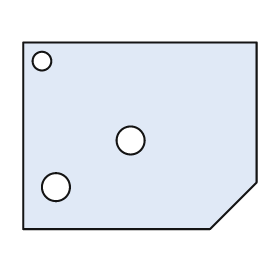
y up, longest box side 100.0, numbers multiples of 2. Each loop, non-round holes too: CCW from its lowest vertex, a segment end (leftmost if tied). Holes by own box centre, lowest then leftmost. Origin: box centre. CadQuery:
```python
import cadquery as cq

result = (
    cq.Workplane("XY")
    .moveTo(-50.0, -40.0)
    .lineTo(30.0, -40.0)
    .lineTo(50.0, -20.0)
    .lineTo(50.0, 40.0)
    .lineTo(-50.0, 40.0)
    .close()
    .moveTo(-36.0, -22.0)
    .circle(6.0)
    .moveTo(-4.0, -2.0)
    .circle(6.0)
    .moveTo(-42.0, 32.0)
    .circle(4.0)
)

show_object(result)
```